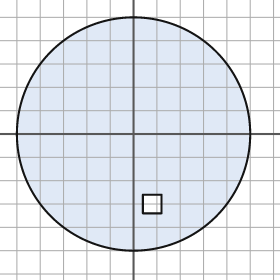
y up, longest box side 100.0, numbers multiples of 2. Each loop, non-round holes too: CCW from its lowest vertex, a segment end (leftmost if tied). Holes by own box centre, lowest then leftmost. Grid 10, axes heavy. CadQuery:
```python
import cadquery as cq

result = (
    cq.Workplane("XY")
    .moveTo(0.0, 0.0)
    .circle(50.0)
    .moveTo(4.0, -34.0)
    .lineTo(12.0, -34.0)
    .lineTo(12.0, -26.0)
    .lineTo(4.0, -26.0)
    .close()
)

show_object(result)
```